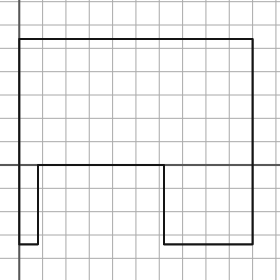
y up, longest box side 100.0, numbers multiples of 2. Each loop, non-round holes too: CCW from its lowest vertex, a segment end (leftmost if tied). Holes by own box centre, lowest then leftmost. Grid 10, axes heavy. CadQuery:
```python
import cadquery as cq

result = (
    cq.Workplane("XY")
    .moveTo(0.0, -34.0)
    .lineTo(8.0, -34.0)
    .lineTo(8.0, 0.0)
    .lineTo(62.0, 0.0)
    .lineTo(62.0, -34.0)
    .lineTo(100.0, -34.0)
    .lineTo(100.0, 54.0)
    .lineTo(0.0, 54.0)
    .close()
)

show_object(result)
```